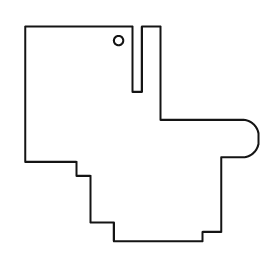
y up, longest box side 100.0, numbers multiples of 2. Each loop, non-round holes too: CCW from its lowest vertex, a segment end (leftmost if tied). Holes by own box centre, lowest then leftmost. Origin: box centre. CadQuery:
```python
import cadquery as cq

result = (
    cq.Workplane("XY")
    .moveTo(-12.0, -46.0)
    .lineTo(26.0, -46.0)
    .lineTo(26.0, -42.0)
    .lineTo(34.0, -42.0)
    .lineTo(34.0, -10.0)
    .lineTo(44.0, -10.0)
    .threePointArc((48.0, -8.0), (50.0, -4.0))
    .lineTo(50.0, 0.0)
    .threePointArc((48.0, 4.0), (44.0, 6.0))
    .lineTo(8.0, 6.0)
    .lineTo(8.0, 46.0)
    .lineTo(0.0, 46.0)
    .lineTo(0.0, 18.0)
    .lineTo(-4.0, 18.0)
    .lineTo(-4.0, 46.0)
    .lineTo(-50.0, 46.0)
    .lineTo(-50.0, -12.0)
    .lineTo(-28.0, -12.0)
    .lineTo(-28.0, -18.0)
    .lineTo(-22.0, -18.0)
    .lineTo(-22.0, -38.0)
    .lineTo(-12.0, -38.0)
    .close()
    .moveTo(-10.0, 40.0)
    .circle(2.0)
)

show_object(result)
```